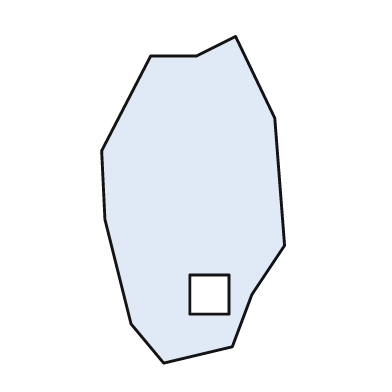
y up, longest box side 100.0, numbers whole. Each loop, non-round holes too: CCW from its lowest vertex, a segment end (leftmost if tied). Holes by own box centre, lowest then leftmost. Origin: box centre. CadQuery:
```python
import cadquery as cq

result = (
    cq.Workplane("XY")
    .moveTo(-9.0, -50.0)
    .lineTo(12.0, -45.0)
    .lineTo(18.0, -29.0)
    .lineTo(28.0, -14.0)
    .lineTo(25.0, 25.0)
    .lineTo(13.0, 50.0)
    .lineTo(1.0, 44.0)
    .lineTo(-13.0, 44.0)
    .lineTo(-28.0, 15.0)
    .lineTo(-27.0, -6.0)
    .lineTo(-19.0, -38.0)
    .close()
    .moveTo(-1.0, -35.0)
    .lineTo(11.0, -35.0)
    .lineTo(11.0, -23.0)
    .lineTo(-1.0, -23.0)
    .close()
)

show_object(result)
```